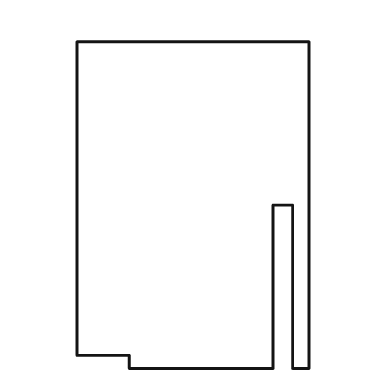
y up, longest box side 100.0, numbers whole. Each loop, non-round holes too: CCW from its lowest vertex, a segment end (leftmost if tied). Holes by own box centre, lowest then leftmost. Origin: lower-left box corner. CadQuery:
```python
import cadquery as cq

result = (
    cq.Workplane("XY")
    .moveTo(16.0, 0.0)
    .lineTo(60.0, 0.0)
    .lineTo(60.0, 50.0)
    .lineTo(66.0, 50.0)
    .lineTo(66.0, 0.0)
    .lineTo(71.0, 0.0)
    .lineTo(71.0, 100.0)
    .lineTo(0.0, 100.0)
    .lineTo(0.0, 4.0)
    .lineTo(16.0, 4.0)
    .close()
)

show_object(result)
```